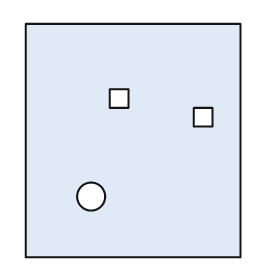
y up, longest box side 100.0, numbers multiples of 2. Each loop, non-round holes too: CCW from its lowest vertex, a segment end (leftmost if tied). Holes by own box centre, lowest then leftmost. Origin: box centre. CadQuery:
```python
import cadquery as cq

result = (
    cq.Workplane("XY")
    .moveTo(-46.0, -50.0)
    .lineTo(46.0, -50.0)
    .lineTo(46.0, 50.0)
    .lineTo(-46.0, 50.0)
    .close()
    .moveTo(-18.0, -24.0)
    .circle(6.0)
    .moveTo(26.0, 6.0)
    .lineTo(34.0, 6.0)
    .lineTo(34.0, 14.0)
    .lineTo(26.0, 14.0)
    .close()
    .moveTo(-10.0, 14.0)
    .lineTo(-2.0, 14.0)
    .lineTo(-2.0, 22.0)
    .lineTo(-10.0, 22.0)
    .close()
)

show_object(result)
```